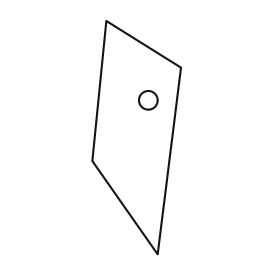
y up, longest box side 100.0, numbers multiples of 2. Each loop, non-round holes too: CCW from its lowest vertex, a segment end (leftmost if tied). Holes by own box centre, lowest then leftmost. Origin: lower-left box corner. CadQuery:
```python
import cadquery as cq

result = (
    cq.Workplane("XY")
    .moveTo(28.0, 0.0)
    .lineTo(38.0, 80.0)
    .lineTo(6.0, 100.0)
    .lineTo(0.0, 40.0)
    .close()
    .moveTo(24.0, 66.0)
    .circle(4.0)
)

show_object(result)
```